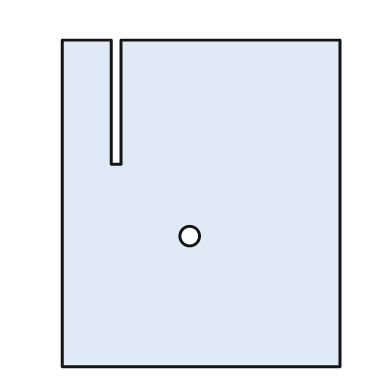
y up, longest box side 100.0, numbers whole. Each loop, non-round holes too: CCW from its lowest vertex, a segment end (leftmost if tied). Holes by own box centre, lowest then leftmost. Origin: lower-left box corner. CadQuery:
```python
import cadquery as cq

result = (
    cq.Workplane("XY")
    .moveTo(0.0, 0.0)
    .lineTo(85.0, 0.0)
    .lineTo(85.0, 100.0)
    .lineTo(18.0, 100.0)
    .lineTo(18.0, 62.0)
    .lineTo(15.0, 62.0)
    .lineTo(15.0, 100.0)
    .lineTo(0.0, 100.0)
    .close()
    .moveTo(39.0, 40.0)
    .circle(3.0)
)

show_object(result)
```